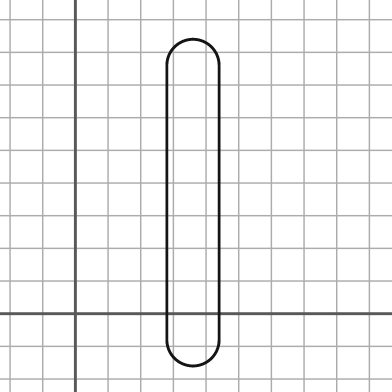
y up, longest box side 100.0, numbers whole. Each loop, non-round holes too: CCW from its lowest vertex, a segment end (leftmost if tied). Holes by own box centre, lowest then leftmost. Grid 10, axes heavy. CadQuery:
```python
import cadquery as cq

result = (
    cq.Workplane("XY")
    .moveTo(28.0, -8.0)
    .threePointArc((36.0, -16.0), (44.0, -8.0))
    .lineTo(44.0, 76.0)
    .threePointArc((36.0, 84.0), (28.0, 76.0))
    .close()
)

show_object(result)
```